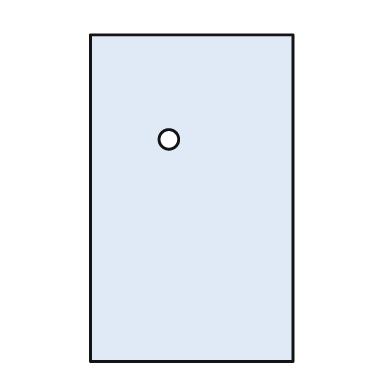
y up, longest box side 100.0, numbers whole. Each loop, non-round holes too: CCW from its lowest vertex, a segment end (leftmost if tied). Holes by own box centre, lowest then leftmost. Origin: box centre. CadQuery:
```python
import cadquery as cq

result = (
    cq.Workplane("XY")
    .moveTo(-31.0, -50.0)
    .lineTo(31.0, -50.0)
    .lineTo(31.0, 50.0)
    .lineTo(-31.0, 50.0)
    .close()
    .moveTo(-7.0, 18.0)
    .circle(3.0)
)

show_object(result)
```